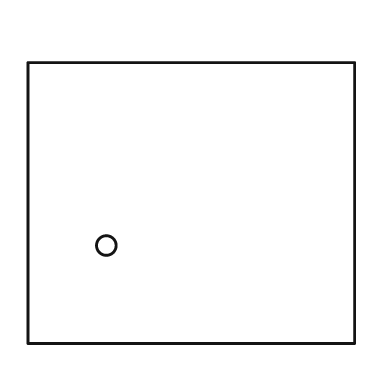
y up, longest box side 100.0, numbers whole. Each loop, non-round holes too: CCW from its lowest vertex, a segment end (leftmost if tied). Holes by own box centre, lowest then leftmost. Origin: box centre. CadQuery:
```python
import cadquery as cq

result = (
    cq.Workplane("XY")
    .moveTo(-50.0, -43.0)
    .lineTo(50.0, -43.0)
    .lineTo(50.0, 43.0)
    .lineTo(-50.0, 43.0)
    .close()
    .moveTo(-26.0, -13.0)
    .circle(3.0)
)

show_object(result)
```